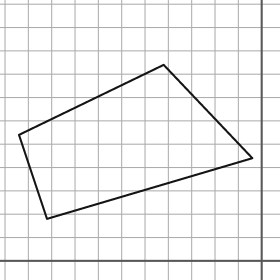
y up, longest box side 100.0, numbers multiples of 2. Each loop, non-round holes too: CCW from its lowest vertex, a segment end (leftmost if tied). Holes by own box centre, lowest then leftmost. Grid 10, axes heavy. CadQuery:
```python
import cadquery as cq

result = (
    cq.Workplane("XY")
    .moveTo(-92.0, 18.0)
    .lineTo(-4.0, 44.0)
    .lineTo(-42.0, 84.0)
    .lineTo(-104.0, 54.0)
    .close()
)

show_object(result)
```